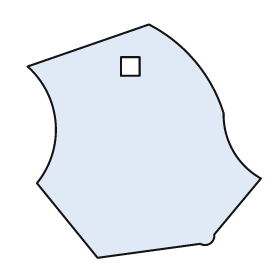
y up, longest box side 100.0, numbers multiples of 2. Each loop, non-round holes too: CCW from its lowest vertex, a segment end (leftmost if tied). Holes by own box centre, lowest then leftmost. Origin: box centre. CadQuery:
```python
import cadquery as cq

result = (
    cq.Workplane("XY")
    .moveTo(-20.0, -50.0)
    .lineTo(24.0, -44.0)
    .threePointArc((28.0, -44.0), (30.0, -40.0))
    .lineTo(50.0, -16.0)
    .threePointArc((38.0, -4.0), (34.0, 12.0))
    .threePointArc((22.0, 34.0), (2.0, 50.0))
    .lineTo(-50.0, 32.0)
    .threePointArc((-38.0, 8.0), (-46.0, -18.0))
    .close()
    .moveTo(-10.0, 28.0)
    .lineTo(-2.0, 28.0)
    .lineTo(-2.0, 36.0)
    .lineTo(-10.0, 36.0)
    .close()
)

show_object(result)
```